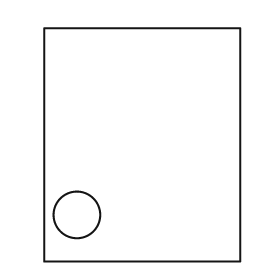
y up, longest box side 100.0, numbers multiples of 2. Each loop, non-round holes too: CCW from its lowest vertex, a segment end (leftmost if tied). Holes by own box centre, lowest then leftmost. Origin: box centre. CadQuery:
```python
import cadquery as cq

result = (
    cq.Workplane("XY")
    .moveTo(-42.0, -50.0)
    .lineTo(42.0, -50.0)
    .lineTo(42.0, 50.0)
    .lineTo(-42.0, 50.0)
    .close()
    .moveTo(-28.0, -30.0)
    .circle(10.0)
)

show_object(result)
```